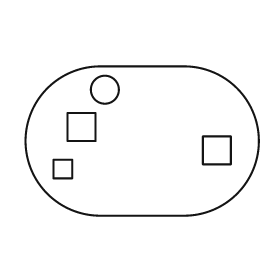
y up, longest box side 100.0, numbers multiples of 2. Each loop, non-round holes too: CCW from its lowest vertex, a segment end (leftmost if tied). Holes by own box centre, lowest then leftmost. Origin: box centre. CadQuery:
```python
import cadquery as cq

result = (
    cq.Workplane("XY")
    .moveTo(-18.0, -32.0)
    .lineTo(18.0, -32.0)
    .threePointArc((50.0, 0.0), (18.0, 32.0))
    .lineTo(-18.0, 32.0)
    .threePointArc((-50.0, 0.0), (-18.0, -32.0))
    .close()
    .moveTo(-38.0, -16.0)
    .lineTo(-30.0, -16.0)
    .lineTo(-30.0, -8.0)
    .lineTo(-38.0, -8.0)
    .close()
    .moveTo(26.0, -10.0)
    .lineTo(38.0, -10.0)
    .lineTo(38.0, 2.0)
    .lineTo(26.0, 2.0)
    .close()
    .moveTo(-32.0, 0.0)
    .lineTo(-20.0, 0.0)
    .lineTo(-20.0, 12.0)
    .lineTo(-32.0, 12.0)
    .close()
    .moveTo(-16.0, 22.0)
    .circle(6.0)
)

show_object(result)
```